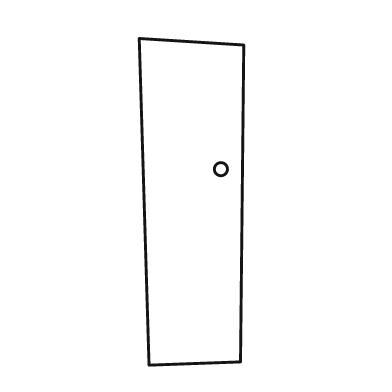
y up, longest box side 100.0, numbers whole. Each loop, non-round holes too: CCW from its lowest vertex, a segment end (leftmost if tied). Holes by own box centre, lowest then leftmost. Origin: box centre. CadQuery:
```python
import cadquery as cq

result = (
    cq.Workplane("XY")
    .moveTo(-13.0, -50.0)
    .lineTo(15.0, -49.0)
    .lineTo(16.0, 48.0)
    .lineTo(-16.0, 50.0)
    .close()
    .moveTo(9.0, 10.0)
    .circle(2.0)
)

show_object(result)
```